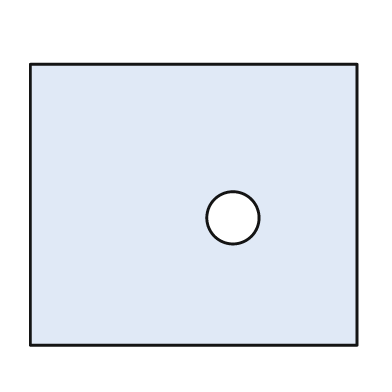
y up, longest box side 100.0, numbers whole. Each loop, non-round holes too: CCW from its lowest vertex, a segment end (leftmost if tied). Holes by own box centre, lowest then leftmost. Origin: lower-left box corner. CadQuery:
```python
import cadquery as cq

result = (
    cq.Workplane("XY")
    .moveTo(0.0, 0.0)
    .lineTo(100.0, 0.0)
    .lineTo(100.0, 86.0)
    .lineTo(0.0, 86.0)
    .close()
    .moveTo(62.0, 39.0)
    .circle(8.0)
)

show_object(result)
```